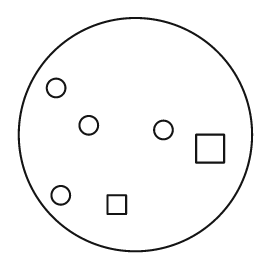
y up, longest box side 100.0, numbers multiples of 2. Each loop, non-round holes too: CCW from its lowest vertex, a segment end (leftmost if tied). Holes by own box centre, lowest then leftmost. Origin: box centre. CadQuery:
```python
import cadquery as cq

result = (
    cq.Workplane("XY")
    .moveTo(0.0, 0.0)
    .circle(50.0)
    .moveTo(-12.0, -34.0)
    .lineTo(-4.0, -34.0)
    .lineTo(-4.0, -26.0)
    .lineTo(-12.0, -26.0)
    .close()
    .moveTo(-32.0, -26.0)
    .circle(4.0)
    .moveTo(26.0, -12.0)
    .lineTo(38.0, -12.0)
    .lineTo(38.0, 0.0)
    .lineTo(26.0, 0.0)
    .close()
    .moveTo(12.0, 2.0)
    .circle(4.0)
    .moveTo(-20.0, 4.0)
    .circle(4.0)
    .moveTo(-34.0, 20.0)
    .circle(4.0)
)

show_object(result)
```